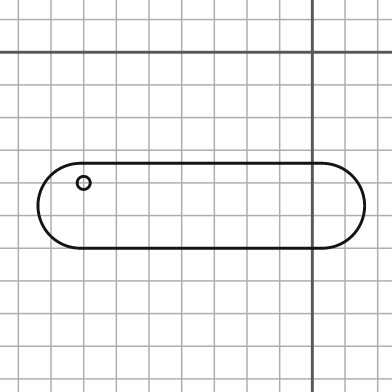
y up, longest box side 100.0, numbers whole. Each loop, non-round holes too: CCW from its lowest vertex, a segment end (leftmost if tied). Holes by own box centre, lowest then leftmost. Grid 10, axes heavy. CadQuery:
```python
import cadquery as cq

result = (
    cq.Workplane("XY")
    .moveTo(-71.0, -60.0)
    .lineTo(3.0, -60.0)
    .threePointArc((16.0, -47.0), (3.0, -34.0))
    .lineTo(-71.0, -34.0)
    .threePointArc((-84.0, -47.0), (-71.0, -60.0))
    .close()
    .moveTo(-70.0, -40.0)
    .circle(2.0)
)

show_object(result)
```